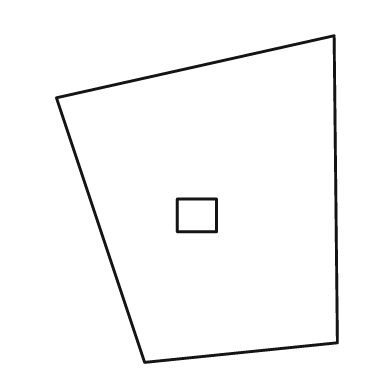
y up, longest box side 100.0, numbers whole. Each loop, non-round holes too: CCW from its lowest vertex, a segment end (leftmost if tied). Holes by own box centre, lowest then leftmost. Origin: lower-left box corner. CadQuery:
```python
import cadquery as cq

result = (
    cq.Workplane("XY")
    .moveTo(27.0, 0.0)
    .lineTo(86.0, 6.0)
    .lineTo(85.0, 100.0)
    .lineTo(0.0, 81.0)
    .close()
    .moveTo(37.0, 40.0)
    .lineTo(49.0, 40.0)
    .lineTo(49.0, 50.0)
    .lineTo(37.0, 50.0)
    .close()
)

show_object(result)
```